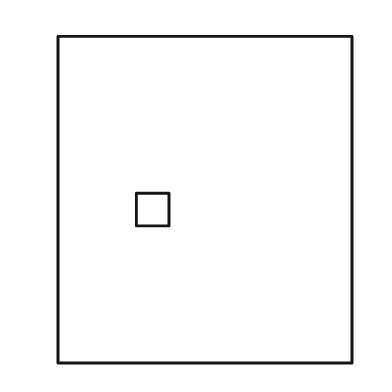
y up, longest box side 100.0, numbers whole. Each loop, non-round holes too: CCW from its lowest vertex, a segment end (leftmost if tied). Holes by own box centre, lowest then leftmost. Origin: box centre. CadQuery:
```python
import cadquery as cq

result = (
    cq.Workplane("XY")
    .moveTo(-45.0, -50.0)
    .lineTo(45.0, -50.0)
    .lineTo(45.0, 50.0)
    .lineTo(-45.0, 50.0)
    .close()
    .moveTo(-21.0, -8.0)
    .lineTo(-11.0, -8.0)
    .lineTo(-11.0, 2.0)
    .lineTo(-21.0, 2.0)
    .close()
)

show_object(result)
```